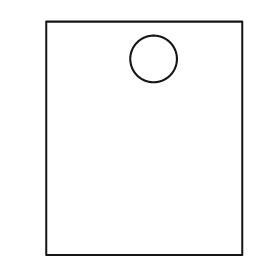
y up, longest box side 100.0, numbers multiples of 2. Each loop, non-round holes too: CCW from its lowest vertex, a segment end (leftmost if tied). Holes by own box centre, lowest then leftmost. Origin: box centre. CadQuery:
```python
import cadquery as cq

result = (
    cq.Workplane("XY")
    .moveTo(-42.0, -50.0)
    .lineTo(42.0, -50.0)
    .lineTo(42.0, 50.0)
    .lineTo(-42.0, 50.0)
    .close()
    .moveTo(4.0, 34.0)
    .circle(10.0)
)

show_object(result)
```